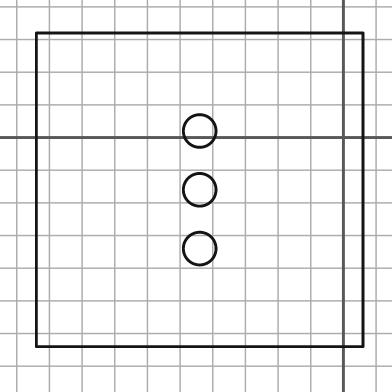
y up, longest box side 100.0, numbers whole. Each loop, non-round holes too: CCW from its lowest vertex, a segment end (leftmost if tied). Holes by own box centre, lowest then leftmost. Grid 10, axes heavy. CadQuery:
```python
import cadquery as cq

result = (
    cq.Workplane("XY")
    .moveTo(-94.0, -64.0)
    .lineTo(6.0, -64.0)
    .lineTo(6.0, 32.0)
    .lineTo(-94.0, 32.0)
    .close()
    .moveTo(-44.0, -34.0)
    .circle(5.0)
    .moveTo(-44.0, -16.0)
    .circle(5.0)
    .moveTo(-44.0, 2.0)
    .circle(5.0)
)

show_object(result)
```